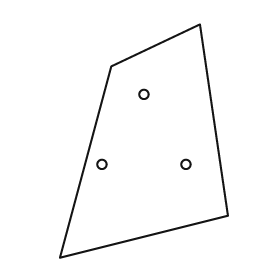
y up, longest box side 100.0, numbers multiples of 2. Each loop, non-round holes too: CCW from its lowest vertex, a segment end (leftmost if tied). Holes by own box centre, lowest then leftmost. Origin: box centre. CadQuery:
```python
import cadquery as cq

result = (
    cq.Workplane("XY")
    .moveTo(-36.0, -50.0)
    .lineTo(36.0, -32.0)
    .lineTo(24.0, 50.0)
    .lineTo(-14.0, 32.0)
    .close()
    .moveTo(-18.0, -10.0)
    .circle(2.0)
    .moveTo(18.0, -10.0)
    .circle(2.0)
    .moveTo(0.0, 20.0)
    .circle(2.0)
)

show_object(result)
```